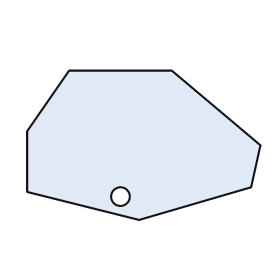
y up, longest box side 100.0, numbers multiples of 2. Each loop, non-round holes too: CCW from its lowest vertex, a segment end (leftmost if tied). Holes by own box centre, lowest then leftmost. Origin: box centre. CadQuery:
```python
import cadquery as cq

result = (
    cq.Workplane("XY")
    .moveTo(-2.0, -32.0)
    .lineTo(46.0, -18.0)
    .lineTo(50.0, 0.0)
    .lineTo(12.0, 32.0)
    .lineTo(-32.0, 32.0)
    .lineTo(-50.0, 6.0)
    .lineTo(-50.0, -20.0)
    .close()
    .moveTo(-10.0, -22.0)
    .circle(4.0)
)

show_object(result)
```